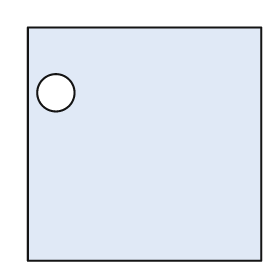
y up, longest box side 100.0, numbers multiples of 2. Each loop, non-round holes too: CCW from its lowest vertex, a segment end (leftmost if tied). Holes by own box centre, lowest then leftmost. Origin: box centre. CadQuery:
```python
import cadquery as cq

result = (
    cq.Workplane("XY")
    .moveTo(-50.0, -50.0)
    .lineTo(50.0, -50.0)
    .lineTo(50.0, 50.0)
    .lineTo(-50.0, 50.0)
    .close()
    .moveTo(-38.0, 22.0)
    .circle(8.0)
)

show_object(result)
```